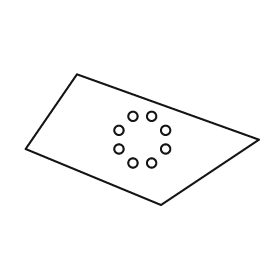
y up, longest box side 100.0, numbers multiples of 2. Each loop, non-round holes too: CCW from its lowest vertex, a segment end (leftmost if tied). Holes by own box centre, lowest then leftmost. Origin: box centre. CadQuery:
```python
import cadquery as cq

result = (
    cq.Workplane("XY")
    .moveTo(8.0, -28.0)
    .lineTo(50.0, 0.0)
    .lineTo(-28.0, 28.0)
    .lineTo(-50.0, -4.0)
    .close()
    .moveTo(-4.0, -10.0)
    .circle(2.0)
    .moveTo(4.0, -10.0)
    .circle(2.0)
    .moveTo(-10.0, -4.0)
    .circle(2.0)
    .moveTo(10.0, -4.0)
    .circle(2.0)
    .moveTo(-10.0, 4.0)
    .circle(2.0)
    .moveTo(10.0, 4.0)
    .circle(2.0)
    .moveTo(-4.0, 10.0)
    .circle(2.0)
    .moveTo(4.0, 10.0)
    .circle(2.0)
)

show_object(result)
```